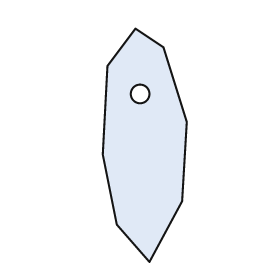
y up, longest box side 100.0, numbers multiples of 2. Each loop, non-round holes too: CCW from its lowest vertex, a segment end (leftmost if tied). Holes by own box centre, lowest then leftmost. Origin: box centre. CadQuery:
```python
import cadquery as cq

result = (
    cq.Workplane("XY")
    .moveTo(2.0, -50.0)
    .lineTo(16.0, -24.0)
    .lineTo(18.0, 10.0)
    .lineTo(8.0, 42.0)
    .lineTo(-4.0, 50.0)
    .lineTo(-16.0, 34.0)
    .lineTo(-18.0, -4.0)
    .lineTo(-12.0, -34.0)
    .close()
    .moveTo(-2.0, 22.0)
    .circle(4.0)
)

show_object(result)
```